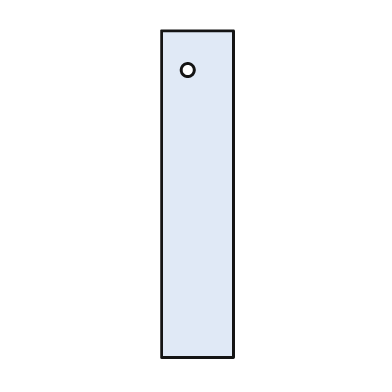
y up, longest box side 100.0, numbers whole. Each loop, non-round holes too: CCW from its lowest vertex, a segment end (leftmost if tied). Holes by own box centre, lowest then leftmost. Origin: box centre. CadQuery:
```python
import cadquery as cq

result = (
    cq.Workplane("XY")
    .moveTo(-11.0, -50.0)
    .lineTo(11.0, -50.0)
    .lineTo(11.0, 50.0)
    .lineTo(-11.0, 50.0)
    .close()
    .moveTo(-3.0, 38.0)
    .circle(2.0)
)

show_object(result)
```